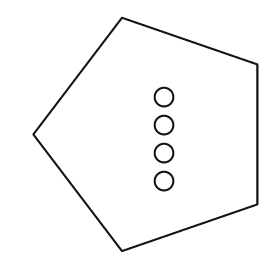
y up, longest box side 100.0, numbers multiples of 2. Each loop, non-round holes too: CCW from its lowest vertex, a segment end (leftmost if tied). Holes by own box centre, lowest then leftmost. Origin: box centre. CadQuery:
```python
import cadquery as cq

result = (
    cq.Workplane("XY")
    .moveTo(-10.0, -50.0)
    .lineTo(48.0, -30.0)
    .lineTo(48.0, 30.0)
    .lineTo(-10.0, 50.0)
    .lineTo(-48.0, 0.0)
    .close()
    .moveTo(8.0, -20.0)
    .circle(4.0)
    .moveTo(8.0, -8.0)
    .circle(4.0)
    .moveTo(8.0, 4.0)
    .circle(4.0)
    .moveTo(8.0, 16.0)
    .circle(4.0)
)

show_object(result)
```